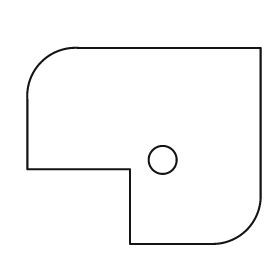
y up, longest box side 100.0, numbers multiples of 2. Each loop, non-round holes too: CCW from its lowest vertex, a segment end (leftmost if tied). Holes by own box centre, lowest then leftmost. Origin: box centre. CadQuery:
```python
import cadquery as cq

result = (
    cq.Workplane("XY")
    .moveTo(-6.0, -42.0)
    .lineTo(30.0, -42.0)
    .threePointArc((44.0, -36.0), (50.0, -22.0))
    .lineTo(50.0, 42.0)
    .lineTo(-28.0, 42.0)
    .threePointArc((-44.0, 36.0), (-50.0, 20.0))
    .lineTo(-50.0, -10.0)
    .lineTo(-6.0, -10.0)
    .close()
    .moveTo(8.0, -6.0)
    .circle(6.0)
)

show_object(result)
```